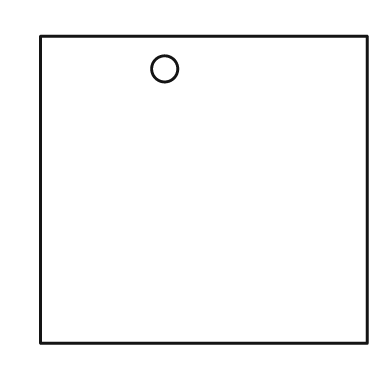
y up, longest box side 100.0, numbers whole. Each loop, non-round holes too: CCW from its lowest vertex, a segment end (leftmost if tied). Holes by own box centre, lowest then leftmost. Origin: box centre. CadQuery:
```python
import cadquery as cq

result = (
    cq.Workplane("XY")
    .moveTo(-50.0, -47.0)
    .lineTo(50.0, -47.0)
    .lineTo(50.0, 47.0)
    .lineTo(-50.0, 47.0)
    .close()
    .moveTo(-12.0, 37.0)
    .circle(4.0)
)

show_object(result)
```